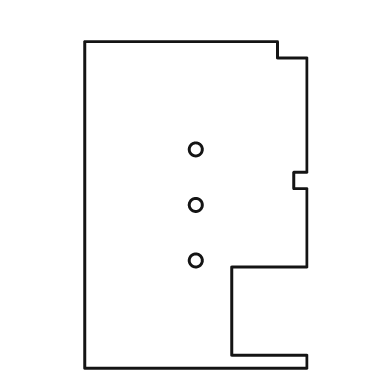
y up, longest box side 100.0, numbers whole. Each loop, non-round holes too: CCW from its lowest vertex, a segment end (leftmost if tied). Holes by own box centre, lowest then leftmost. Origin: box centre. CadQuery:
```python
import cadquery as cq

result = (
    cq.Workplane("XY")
    .moveTo(-34.0, -50.0)
    .lineTo(34.0, -50.0)
    .lineTo(34.0, -46.0)
    .lineTo(11.0, -46.0)
    .lineTo(11.0, -19.0)
    .lineTo(34.0, -19.0)
    .lineTo(34.0, 5.0)
    .lineTo(30.0, 5.0)
    .lineTo(30.0, 10.0)
    .lineTo(34.0, 10.0)
    .lineTo(34.0, 45.0)
    .lineTo(25.0, 45.0)
    .lineTo(25.0, 50.0)
    .lineTo(-34.0, 50.0)
    .close()
    .moveTo(0.0, -17.0)
    .circle(2.0)
    .moveTo(0.0, 0.0)
    .circle(2.0)
    .moveTo(0.0, 17.0)
    .circle(2.0)
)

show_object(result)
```